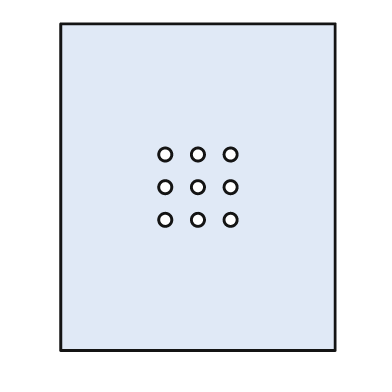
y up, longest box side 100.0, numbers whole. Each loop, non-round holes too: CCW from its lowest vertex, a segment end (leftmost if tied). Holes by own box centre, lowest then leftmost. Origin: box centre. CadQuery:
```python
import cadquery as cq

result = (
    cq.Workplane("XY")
    .moveTo(-42.0, -50.0)
    .lineTo(42.0, -50.0)
    .lineTo(42.0, 50.0)
    .lineTo(-42.0, 50.0)
    .close()
    .moveTo(-10.0, -10.0)
    .circle(2.0)
    .moveTo(0.0, -10.0)
    .circle(2.0)
    .moveTo(10.0, -10.0)
    .circle(2.0)
    .moveTo(-10.0, 0.0)
    .circle(2.0)
    .moveTo(0.0, 0.0)
    .circle(2.0)
    .moveTo(10.0, 0.0)
    .circle(2.0)
    .moveTo(-10.0, 10.0)
    .circle(2.0)
    .moveTo(0.0, 10.0)
    .circle(2.0)
    .moveTo(10.0, 10.0)
    .circle(2.0)
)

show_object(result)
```